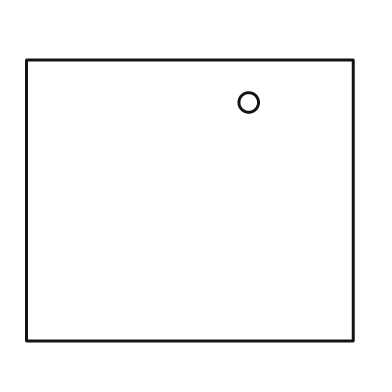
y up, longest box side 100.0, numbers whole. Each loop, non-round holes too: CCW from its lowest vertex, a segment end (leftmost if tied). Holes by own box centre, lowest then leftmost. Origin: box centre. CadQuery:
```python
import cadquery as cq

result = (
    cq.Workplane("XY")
    .moveTo(-50.0, -43.0)
    .lineTo(50.0, -43.0)
    .lineTo(50.0, 43.0)
    .lineTo(-50.0, 43.0)
    .close()
    .moveTo(18.0, 30.0)
    .circle(3.0)
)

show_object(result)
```